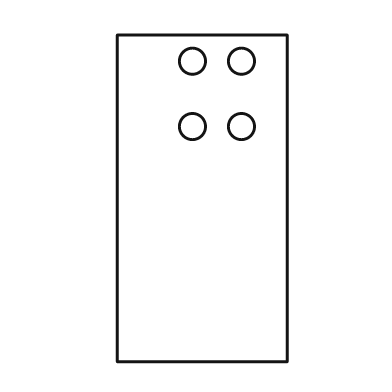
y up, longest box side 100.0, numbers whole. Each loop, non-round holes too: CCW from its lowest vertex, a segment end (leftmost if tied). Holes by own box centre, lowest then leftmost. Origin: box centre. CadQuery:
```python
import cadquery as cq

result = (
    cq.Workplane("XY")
    .moveTo(-26.0, -50.0)
    .lineTo(26.0, -50.0)
    .lineTo(26.0, 50.0)
    .lineTo(-26.0, 50.0)
    .close()
    .moveTo(-3.0, 22.0)
    .circle(4.0)
    .moveTo(12.0, 22.0)
    .circle(4.0)
    .moveTo(-3.0, 42.0)
    .circle(4.0)
    .moveTo(12.0, 42.0)
    .circle(4.0)
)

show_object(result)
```